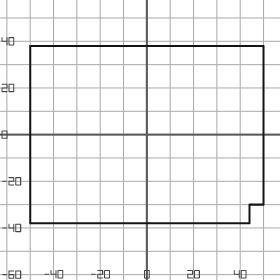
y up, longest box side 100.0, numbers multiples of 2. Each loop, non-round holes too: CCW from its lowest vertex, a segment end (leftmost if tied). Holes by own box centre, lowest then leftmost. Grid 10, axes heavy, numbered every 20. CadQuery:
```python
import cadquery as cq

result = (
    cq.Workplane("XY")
    .moveTo(-50.0, -38.0)
    .lineTo(44.0, -38.0)
    .lineTo(44.0, -30.0)
    .lineTo(50.0, -30.0)
    .lineTo(50.0, 38.0)
    .lineTo(-50.0, 38.0)
    .close()
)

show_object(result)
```